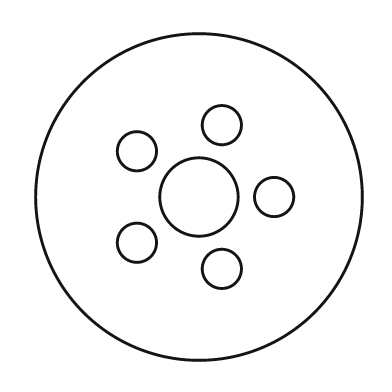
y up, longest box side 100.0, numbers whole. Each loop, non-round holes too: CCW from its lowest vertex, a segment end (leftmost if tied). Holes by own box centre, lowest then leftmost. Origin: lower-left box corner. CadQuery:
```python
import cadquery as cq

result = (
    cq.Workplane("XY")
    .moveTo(50.0, 50.0)
    .circle(50.0)
    .moveTo(57.0, 28.0)
    .circle(6.0)
    .moveTo(31.0, 36.0)
    .circle(6.0)
    .moveTo(50.0, 50.0)
    .circle(12.0)
    .moveTo(73.0, 50.0)
    .circle(6.0)
    .moveTo(31.0, 64.0)
    .circle(6.0)
    .moveTo(57.0, 72.0)
    .circle(6.0)
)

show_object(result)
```